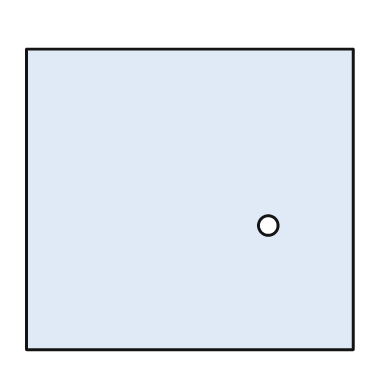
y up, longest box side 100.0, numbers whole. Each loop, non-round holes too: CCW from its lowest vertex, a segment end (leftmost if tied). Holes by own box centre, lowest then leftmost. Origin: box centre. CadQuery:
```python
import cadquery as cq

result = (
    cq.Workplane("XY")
    .moveTo(-50.0, -46.0)
    .lineTo(50.0, -46.0)
    .lineTo(50.0, 46.0)
    .lineTo(-50.0, 46.0)
    .close()
    .moveTo(24.0, -8.0)
    .circle(3.0)
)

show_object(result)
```